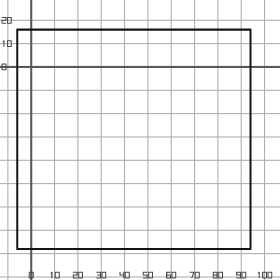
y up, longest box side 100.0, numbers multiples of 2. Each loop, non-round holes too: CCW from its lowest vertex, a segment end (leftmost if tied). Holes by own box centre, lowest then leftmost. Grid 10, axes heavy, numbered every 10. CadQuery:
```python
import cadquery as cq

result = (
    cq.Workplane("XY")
    .moveTo(-6.0, -78.0)
    .lineTo(94.0, -78.0)
    .lineTo(94.0, 16.0)
    .lineTo(-6.0, 16.0)
    .close()
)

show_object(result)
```